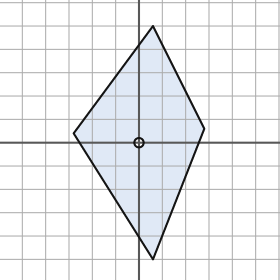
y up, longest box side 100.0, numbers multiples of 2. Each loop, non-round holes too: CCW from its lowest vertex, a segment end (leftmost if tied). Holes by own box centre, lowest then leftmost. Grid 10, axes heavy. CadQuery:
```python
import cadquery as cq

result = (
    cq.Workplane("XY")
    .moveTo(6.0, -50.0)
    .lineTo(28.0, 6.0)
    .lineTo(6.0, 50.0)
    .lineTo(-28.0, 4.0)
    .close()
    .moveTo(0.0, 0.0)
    .circle(2.0)
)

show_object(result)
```